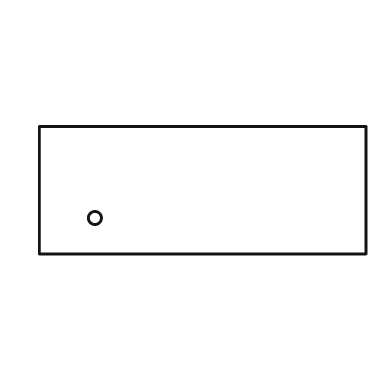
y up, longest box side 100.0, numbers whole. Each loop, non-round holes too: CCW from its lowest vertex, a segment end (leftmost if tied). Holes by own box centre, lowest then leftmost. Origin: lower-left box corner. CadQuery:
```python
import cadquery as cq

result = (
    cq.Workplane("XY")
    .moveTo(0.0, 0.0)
    .lineTo(100.0, 0.0)
    .lineTo(100.0, 39.0)
    .lineTo(0.0, 39.0)
    .close()
    .moveTo(17.0, 11.0)
    .circle(2.0)
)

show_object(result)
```